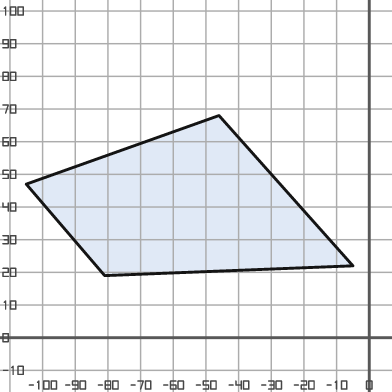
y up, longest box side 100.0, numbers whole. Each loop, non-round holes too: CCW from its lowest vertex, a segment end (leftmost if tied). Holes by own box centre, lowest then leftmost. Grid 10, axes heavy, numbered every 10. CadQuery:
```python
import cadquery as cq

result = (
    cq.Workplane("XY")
    .moveTo(-81.0, 19.0)
    .lineTo(-5.0, 22.0)
    .lineTo(-46.0, 68.0)
    .lineTo(-105.0, 47.0)
    .close()
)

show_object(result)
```